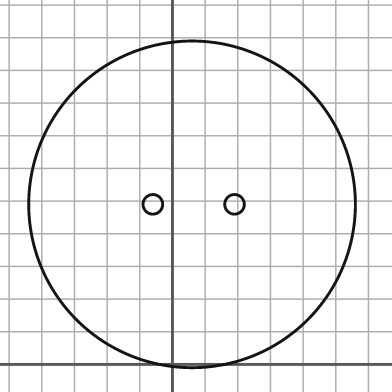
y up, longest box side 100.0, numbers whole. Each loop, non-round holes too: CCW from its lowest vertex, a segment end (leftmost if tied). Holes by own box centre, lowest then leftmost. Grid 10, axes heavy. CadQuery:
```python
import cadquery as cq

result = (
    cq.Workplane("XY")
    .moveTo(6.0, 49.0)
    .circle(50.0)
    .moveTo(-6.0, 49.0)
    .circle(3.0)
    .moveTo(19.0, 49.0)
    .circle(3.0)
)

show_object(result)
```